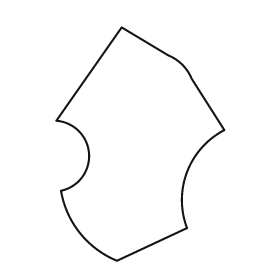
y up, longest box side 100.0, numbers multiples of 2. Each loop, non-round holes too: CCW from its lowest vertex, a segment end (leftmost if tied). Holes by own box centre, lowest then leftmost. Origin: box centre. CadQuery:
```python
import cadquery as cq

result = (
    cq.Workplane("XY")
    .moveTo(-10.0, -50.0)
    .lineTo(20.0, -36.0)
    .threePointArc((20.0, -12.0), (36.0, 6.0))
    .lineTo(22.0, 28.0)
    .threePointArc((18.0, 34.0), (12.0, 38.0))
    .lineTo(-8.0, 50.0)
    .lineTo(-36.0, 10.0)
    .threePointArc((-22.0, -4.0), (-34.0, -20.0))
    .threePointArc((-26.0, -38.0), (-10.0, -50.0))
    .close()
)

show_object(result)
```